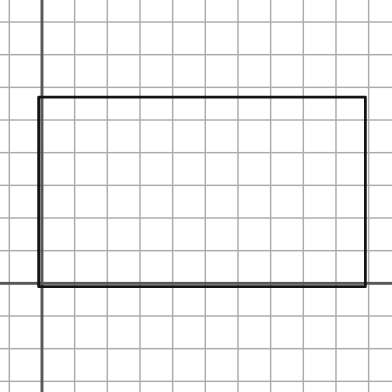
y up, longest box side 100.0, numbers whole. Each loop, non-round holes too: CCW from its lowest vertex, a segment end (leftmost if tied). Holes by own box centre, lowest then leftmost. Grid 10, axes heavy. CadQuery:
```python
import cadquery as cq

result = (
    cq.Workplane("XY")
    .moveTo(-1.0, -1.0)
    .lineTo(99.0, -1.0)
    .lineTo(99.0, 57.0)
    .lineTo(-1.0, 57.0)
    .close()
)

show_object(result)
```